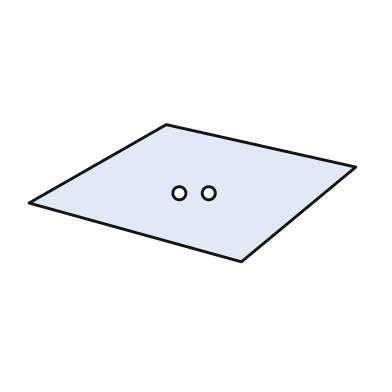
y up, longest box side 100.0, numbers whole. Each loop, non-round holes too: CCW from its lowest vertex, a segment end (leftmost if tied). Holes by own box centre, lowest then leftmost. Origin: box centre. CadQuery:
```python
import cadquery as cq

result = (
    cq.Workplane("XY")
    .moveTo(15.0, -21.0)
    .lineTo(50.0, 8.0)
    .lineTo(-8.0, 21.0)
    .lineTo(-50.0, -3.0)
    .close()
    .moveTo(-4.0, 0.0)
    .circle(2.0)
    .moveTo(5.0, 0.0)
    .circle(2.0)
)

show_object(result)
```